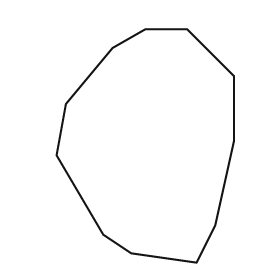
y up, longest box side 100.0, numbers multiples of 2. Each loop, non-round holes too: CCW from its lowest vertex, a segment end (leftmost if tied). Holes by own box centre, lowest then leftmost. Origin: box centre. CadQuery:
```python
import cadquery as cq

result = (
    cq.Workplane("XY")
    .moveTo(22.0, -50.0)
    .lineTo(30.0, -34.0)
    .lineTo(38.0, 2.0)
    .lineTo(38.0, 30.0)
    .lineTo(18.0, 50.0)
    .lineTo(0.0, 50.0)
    .lineTo(-14.0, 42.0)
    .lineTo(-34.0, 18.0)
    .lineTo(-38.0, -4.0)
    .lineTo(-18.0, -38.0)
    .lineTo(-6.0, -46.0)
    .close()
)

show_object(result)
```